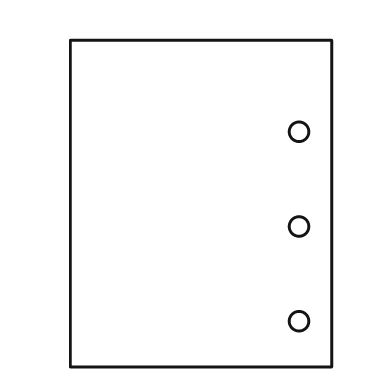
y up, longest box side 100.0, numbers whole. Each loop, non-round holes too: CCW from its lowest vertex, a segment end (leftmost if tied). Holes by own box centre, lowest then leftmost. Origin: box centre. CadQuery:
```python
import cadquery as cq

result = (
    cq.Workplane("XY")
    .moveTo(-40.0, -50.0)
    .lineTo(40.0, -50.0)
    .lineTo(40.0, 50.0)
    .lineTo(-40.0, 50.0)
    .close()
    .moveTo(30.0, -36.0)
    .circle(3.0)
    .moveTo(30.0, -7.0)
    .circle(3.0)
    .moveTo(30.0, 22.0)
    .circle(3.0)
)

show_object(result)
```